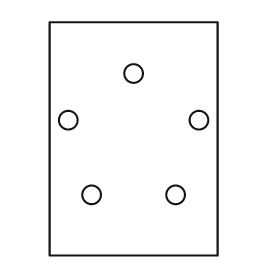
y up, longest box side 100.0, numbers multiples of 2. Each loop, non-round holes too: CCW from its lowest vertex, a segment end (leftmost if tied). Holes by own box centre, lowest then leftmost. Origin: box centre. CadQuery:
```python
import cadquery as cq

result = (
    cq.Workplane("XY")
    .moveTo(-36.0, -50.0)
    .lineTo(36.0, -50.0)
    .lineTo(36.0, 50.0)
    .lineTo(-36.0, 50.0)
    .close()
    .moveTo(-18.0, -24.0)
    .circle(4.0)
    .moveTo(18.0, -24.0)
    .circle(4.0)
    .moveTo(-28.0, 8.0)
    .circle(4.0)
    .moveTo(28.0, 8.0)
    .circle(4.0)
    .moveTo(0.0, 28.0)
    .circle(4.0)
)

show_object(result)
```